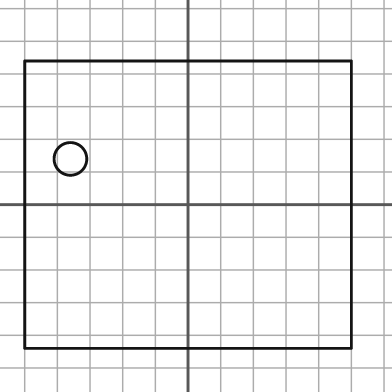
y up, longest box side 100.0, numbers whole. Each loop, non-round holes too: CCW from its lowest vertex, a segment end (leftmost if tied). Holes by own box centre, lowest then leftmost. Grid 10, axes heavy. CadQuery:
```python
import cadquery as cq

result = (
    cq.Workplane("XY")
    .moveTo(-50.0, -44.0)
    .lineTo(50.0, -44.0)
    .lineTo(50.0, 44.0)
    .lineTo(-50.0, 44.0)
    .close()
    .moveTo(-36.0, 14.0)
    .circle(5.0)
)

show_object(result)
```